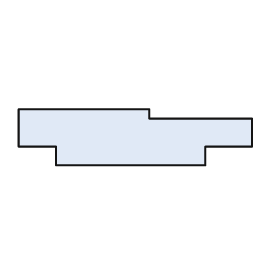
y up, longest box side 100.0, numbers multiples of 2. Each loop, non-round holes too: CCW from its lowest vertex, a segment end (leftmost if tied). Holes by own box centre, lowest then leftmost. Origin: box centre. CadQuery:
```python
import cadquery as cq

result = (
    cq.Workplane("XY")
    .moveTo(-34.0, -12.0)
    .lineTo(30.0, -12.0)
    .lineTo(30.0, -4.0)
    .lineTo(50.0, -4.0)
    .lineTo(50.0, 8.0)
    .lineTo(6.0, 8.0)
    .lineTo(6.0, 12.0)
    .lineTo(-50.0, 12.0)
    .lineTo(-50.0, -4.0)
    .lineTo(-34.0, -4.0)
    .close()
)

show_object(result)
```